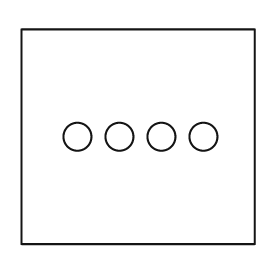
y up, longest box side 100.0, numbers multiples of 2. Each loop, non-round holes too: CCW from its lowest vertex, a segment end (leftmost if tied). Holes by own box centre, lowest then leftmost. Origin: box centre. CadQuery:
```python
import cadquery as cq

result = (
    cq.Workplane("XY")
    .moveTo(-50.0, -46.0)
    .lineTo(50.0, -46.0)
    .lineTo(50.0, 46.0)
    .lineTo(-50.0, 46.0)
    .close()
    .moveTo(-26.0, 0.0)
    .circle(6.0)
    .moveTo(-8.0, 0.0)
    .circle(6.0)
    .moveTo(10.0, 0.0)
    .circle(6.0)
    .moveTo(28.0, 0.0)
    .circle(6.0)
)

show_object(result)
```